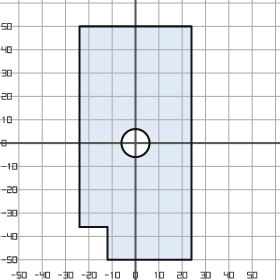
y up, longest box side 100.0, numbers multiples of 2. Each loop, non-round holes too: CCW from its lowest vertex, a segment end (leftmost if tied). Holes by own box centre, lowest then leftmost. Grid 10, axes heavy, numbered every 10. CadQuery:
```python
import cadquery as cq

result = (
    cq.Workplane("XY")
    .moveTo(-12.0, -50.0)
    .lineTo(24.0, -50.0)
    .lineTo(24.0, 50.0)
    .lineTo(-24.0, 50.0)
    .lineTo(-24.0, -36.0)
    .lineTo(-12.0, -36.0)
    .close()
    .moveTo(0.0, 0.0)
    .circle(6.0)
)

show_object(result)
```